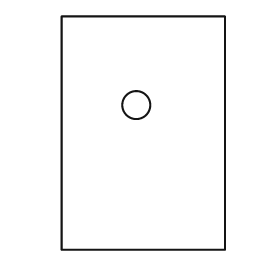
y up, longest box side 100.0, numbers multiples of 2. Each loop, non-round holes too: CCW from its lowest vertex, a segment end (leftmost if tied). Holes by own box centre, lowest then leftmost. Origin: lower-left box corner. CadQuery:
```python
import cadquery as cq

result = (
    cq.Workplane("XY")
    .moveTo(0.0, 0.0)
    .lineTo(70.0, 0.0)
    .lineTo(70.0, 100.0)
    .lineTo(0.0, 100.0)
    .close()
    .moveTo(32.0, 62.0)
    .circle(6.0)
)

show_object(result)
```